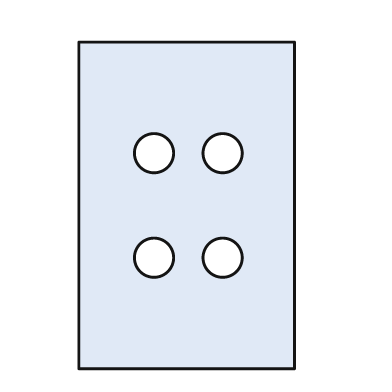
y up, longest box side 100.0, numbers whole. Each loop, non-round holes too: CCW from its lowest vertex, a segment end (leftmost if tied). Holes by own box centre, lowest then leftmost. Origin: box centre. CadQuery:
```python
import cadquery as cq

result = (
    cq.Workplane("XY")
    .moveTo(-33.0, -50.0)
    .lineTo(33.0, -50.0)
    .lineTo(33.0, 50.0)
    .lineTo(-33.0, 50.0)
    .close()
    .moveTo(-10.0, -16.0)
    .circle(6.0)
    .moveTo(11.0, -16.0)
    .circle(6.0)
    .moveTo(-10.0, 16.0)
    .circle(6.0)
    .moveTo(11.0, 16.0)
    .circle(6.0)
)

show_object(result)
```